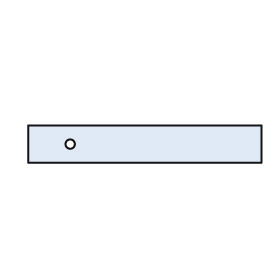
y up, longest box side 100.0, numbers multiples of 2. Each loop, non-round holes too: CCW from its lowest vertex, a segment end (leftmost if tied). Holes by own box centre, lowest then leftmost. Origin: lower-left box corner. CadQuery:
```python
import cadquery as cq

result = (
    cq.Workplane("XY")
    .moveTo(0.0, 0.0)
    .lineTo(100.0, 0.0)
    .lineTo(100.0, 16.0)
    .lineTo(0.0, 16.0)
    .close()
    .moveTo(18.0, 8.0)
    .circle(2.0)
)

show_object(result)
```